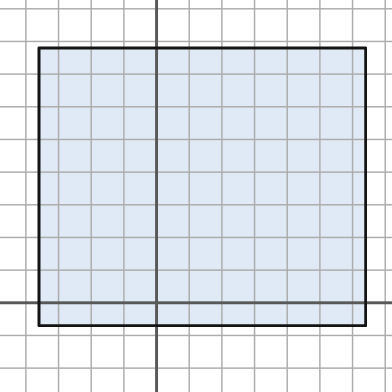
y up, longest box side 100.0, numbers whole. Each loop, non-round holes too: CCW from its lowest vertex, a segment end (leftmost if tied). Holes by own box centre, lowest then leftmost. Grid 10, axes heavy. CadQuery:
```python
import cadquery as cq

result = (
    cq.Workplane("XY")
    .moveTo(-36.0, -7.0)
    .lineTo(64.0, -7.0)
    .lineTo(64.0, 78.0)
    .lineTo(-36.0, 78.0)
    .close()
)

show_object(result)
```